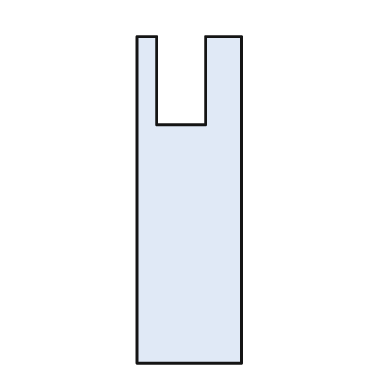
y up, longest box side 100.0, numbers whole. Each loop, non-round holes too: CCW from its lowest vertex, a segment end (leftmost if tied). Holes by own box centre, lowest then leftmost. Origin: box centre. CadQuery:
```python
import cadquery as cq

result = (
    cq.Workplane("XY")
    .moveTo(-16.0, -50.0)
    .lineTo(16.0, -50.0)
    .lineTo(16.0, 50.0)
    .lineTo(5.0, 50.0)
    .lineTo(5.0, 23.0)
    .lineTo(-10.0, 23.0)
    .lineTo(-10.0, 50.0)
    .lineTo(-16.0, 50.0)
    .close()
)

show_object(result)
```